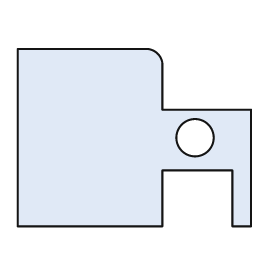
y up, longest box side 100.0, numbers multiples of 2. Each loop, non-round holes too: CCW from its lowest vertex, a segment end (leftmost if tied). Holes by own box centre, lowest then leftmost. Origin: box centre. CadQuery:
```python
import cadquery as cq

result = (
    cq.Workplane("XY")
    .moveTo(-50.0, -38.0)
    .lineTo(12.0, -38.0)
    .lineTo(12.0, -14.0)
    .lineTo(42.0, -14.0)
    .lineTo(42.0, -38.0)
    .lineTo(50.0, -38.0)
    .lineTo(50.0, 12.0)
    .lineTo(12.0, 12.0)
    .lineTo(12.0, 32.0)
    .threePointArc((10.0, 36.0), (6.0, 38.0))
    .lineTo(-50.0, 38.0)
    .close()
    .moveTo(26.0, 0.0)
    .circle(8.0)
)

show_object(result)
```